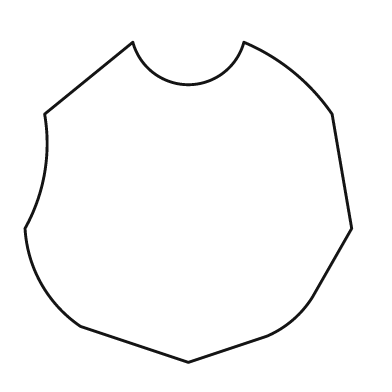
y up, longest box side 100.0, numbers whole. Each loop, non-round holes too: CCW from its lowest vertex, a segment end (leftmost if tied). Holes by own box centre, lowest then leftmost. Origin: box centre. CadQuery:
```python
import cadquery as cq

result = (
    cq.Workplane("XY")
    .moveTo(0.0, -49.0)
    .lineTo(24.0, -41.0)
    .threePointArc((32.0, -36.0), (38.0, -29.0))
    .lineTo(50.0, -8.0)
    .lineTo(44.0, 27.0)
    .threePointArc((32.0, 40.0), (17.0, 49.0))
    .threePointArc((0.0, 36.0), (-17.0, 49.0))
    .lineTo(-44.0, 27.0)
    .threePointArc((-44.0, 9.0), (-50.0, -8.0))
    .threePointArc((-45.0, -25.0), (-33.0, -38.0))
    .close()
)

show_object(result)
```